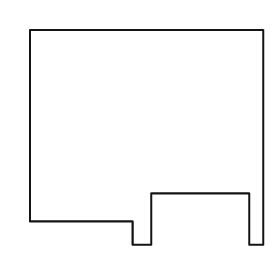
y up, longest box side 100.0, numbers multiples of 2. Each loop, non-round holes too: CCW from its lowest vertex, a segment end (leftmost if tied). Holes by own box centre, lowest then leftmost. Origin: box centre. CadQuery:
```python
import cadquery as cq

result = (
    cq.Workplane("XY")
    .moveTo(-6.0, -46.0)
    .lineTo(2.0, -46.0)
    .lineTo(2.0, -24.0)
    .lineTo(44.0, -24.0)
    .lineTo(44.0, -46.0)
    .lineTo(50.0, -46.0)
    .lineTo(50.0, 46.0)
    .lineTo(-50.0, 46.0)
    .lineTo(-50.0, -36.0)
    .lineTo(-6.0, -36.0)
    .close()
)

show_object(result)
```